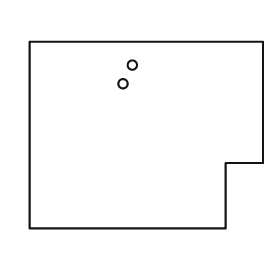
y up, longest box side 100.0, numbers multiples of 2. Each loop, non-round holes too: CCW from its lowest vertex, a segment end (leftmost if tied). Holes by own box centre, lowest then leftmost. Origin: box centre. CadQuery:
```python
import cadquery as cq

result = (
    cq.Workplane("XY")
    .moveTo(-50.0, -40.0)
    .lineTo(34.0, -40.0)
    .lineTo(34.0, -12.0)
    .lineTo(50.0, -12.0)
    .lineTo(50.0, 40.0)
    .lineTo(-50.0, 40.0)
    .close()
    .moveTo(-10.0, 22.0)
    .circle(2.0)
    .moveTo(-6.0, 30.0)
    .circle(2.0)
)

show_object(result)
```